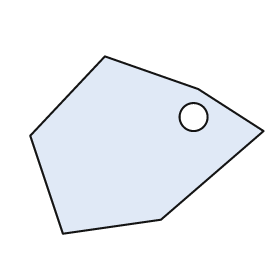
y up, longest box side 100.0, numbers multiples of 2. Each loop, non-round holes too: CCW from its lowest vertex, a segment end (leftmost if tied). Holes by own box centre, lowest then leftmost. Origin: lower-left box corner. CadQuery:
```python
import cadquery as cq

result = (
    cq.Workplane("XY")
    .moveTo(14.0, 0.0)
    .lineTo(56.0, 6.0)
    .lineTo(100.0, 44.0)
    .lineTo(72.0, 62.0)
    .lineTo(32.0, 76.0)
    .lineTo(0.0, 42.0)
    .close()
    .moveTo(70.0, 50.0)
    .circle(6.0)
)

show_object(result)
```